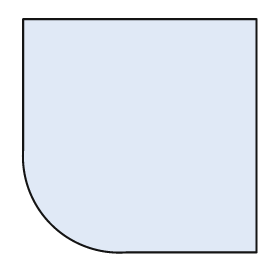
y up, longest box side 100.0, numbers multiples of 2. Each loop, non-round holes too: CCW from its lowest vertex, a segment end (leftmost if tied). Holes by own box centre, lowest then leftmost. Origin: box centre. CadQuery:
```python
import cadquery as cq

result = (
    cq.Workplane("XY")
    .moveTo(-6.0, -50.0)
    .lineTo(50.0, -50.0)
    .lineTo(50.0, 50.0)
    .lineTo(-50.0, 50.0)
    .lineTo(-50.0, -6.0)
    .threePointArc((-38.0, -38.0), (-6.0, -50.0))
    .close()
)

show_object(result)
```